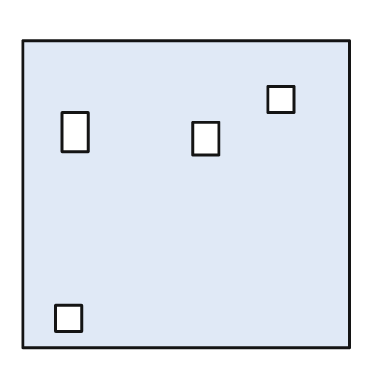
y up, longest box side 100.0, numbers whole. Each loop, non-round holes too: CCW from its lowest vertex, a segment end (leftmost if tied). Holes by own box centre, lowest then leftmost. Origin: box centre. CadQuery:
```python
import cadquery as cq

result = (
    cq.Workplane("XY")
    .moveTo(-50.0, -47.0)
    .lineTo(50.0, -47.0)
    .lineTo(50.0, 47.0)
    .lineTo(-50.0, 47.0)
    .close()
    .moveTo(-40.0, -42.0)
    .lineTo(-32.0, -42.0)
    .lineTo(-32.0, -34.0)
    .lineTo(-40.0, -34.0)
    .close()
    .moveTo(2.0, 12.0)
    .lineTo(10.0, 12.0)
    .lineTo(10.0, 22.0)
    .lineTo(2.0, 22.0)
    .close()
    .moveTo(-38.0, 13.0)
    .lineTo(-30.0, 13.0)
    .lineTo(-30.0, 25.0)
    .lineTo(-38.0, 25.0)
    .close()
    .moveTo(25.0, 25.0)
    .lineTo(33.0, 25.0)
    .lineTo(33.0, 33.0)
    .lineTo(25.0, 33.0)
    .close()
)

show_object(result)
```